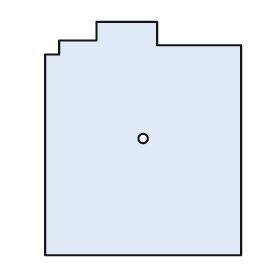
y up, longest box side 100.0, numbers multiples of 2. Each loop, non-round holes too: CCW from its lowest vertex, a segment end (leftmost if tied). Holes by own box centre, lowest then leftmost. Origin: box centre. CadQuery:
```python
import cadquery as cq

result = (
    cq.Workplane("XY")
    .moveTo(-42.0, -50.0)
    .lineTo(42.0, -50.0)
    .lineTo(42.0, 40.0)
    .lineTo(6.0, 40.0)
    .lineTo(6.0, 50.0)
    .lineTo(-20.0, 50.0)
    .lineTo(-20.0, 42.0)
    .lineTo(-36.0, 42.0)
    .lineTo(-36.0, 36.0)
    .lineTo(-42.0, 36.0)
    .close()
    .moveTo(0.0, 0.0)
    .circle(2.0)
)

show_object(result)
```